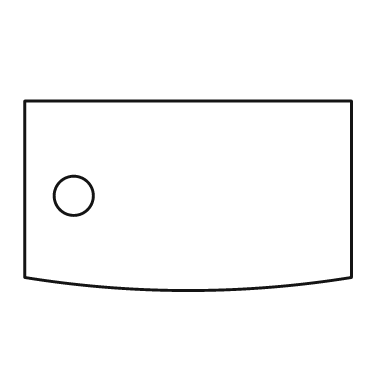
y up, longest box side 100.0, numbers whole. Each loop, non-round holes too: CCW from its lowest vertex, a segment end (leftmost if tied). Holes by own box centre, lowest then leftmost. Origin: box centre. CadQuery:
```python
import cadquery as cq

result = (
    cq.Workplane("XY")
    .moveTo(-50.0, -25.0)
    .threePointArc((0.0, -29.0), (50.0, -25.0))
    .lineTo(50.0, 29.0)
    .lineTo(-50.0, 29.0)
    .close()
    .moveTo(-35.0, 0.0)
    .circle(6.0)
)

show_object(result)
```